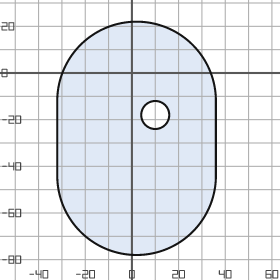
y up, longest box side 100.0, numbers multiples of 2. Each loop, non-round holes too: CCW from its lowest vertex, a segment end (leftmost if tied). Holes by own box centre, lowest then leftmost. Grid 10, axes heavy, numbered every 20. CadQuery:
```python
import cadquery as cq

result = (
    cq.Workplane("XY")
    .moveTo(-32.0, -44.0)
    .threePointArc((2.0, -78.0), (36.0, -44.0))
    .lineTo(36.0, -12.0)
    .threePointArc((2.0, 22.0), (-32.0, -12.0))
    .close()
    .moveTo(10.0, -18.0)
    .circle(6.0)
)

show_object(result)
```